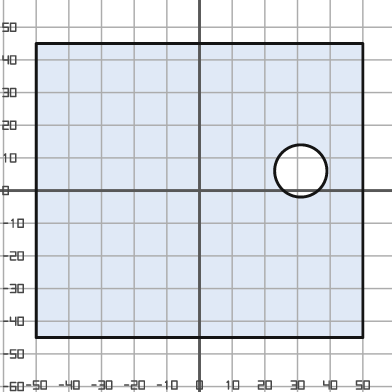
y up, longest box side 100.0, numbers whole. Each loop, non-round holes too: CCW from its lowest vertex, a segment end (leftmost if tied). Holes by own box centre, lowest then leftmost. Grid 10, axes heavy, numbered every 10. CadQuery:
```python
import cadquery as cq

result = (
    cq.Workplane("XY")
    .moveTo(-50.0, -45.0)
    .lineTo(50.0, -45.0)
    .lineTo(50.0, 45.0)
    .lineTo(-50.0, 45.0)
    .close()
    .moveTo(31.0, 6.0)
    .circle(8.0)
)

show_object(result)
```